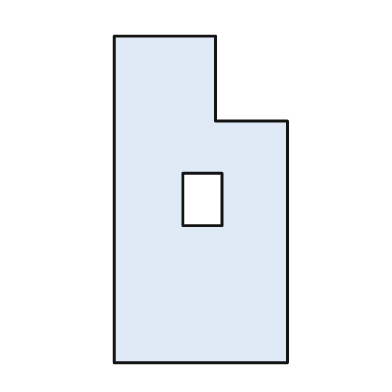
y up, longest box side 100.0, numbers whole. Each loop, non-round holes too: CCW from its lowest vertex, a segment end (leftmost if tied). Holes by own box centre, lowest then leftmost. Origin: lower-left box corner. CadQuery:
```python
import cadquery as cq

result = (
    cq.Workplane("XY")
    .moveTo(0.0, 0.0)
    .lineTo(53.0, 0.0)
    .lineTo(53.0, 74.0)
    .lineTo(31.0, 74.0)
    .lineTo(31.0, 100.0)
    .lineTo(0.0, 100.0)
    .close()
    .moveTo(21.0, 42.0)
    .lineTo(33.0, 42.0)
    .lineTo(33.0, 58.0)
    .lineTo(21.0, 58.0)
    .close()
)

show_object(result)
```